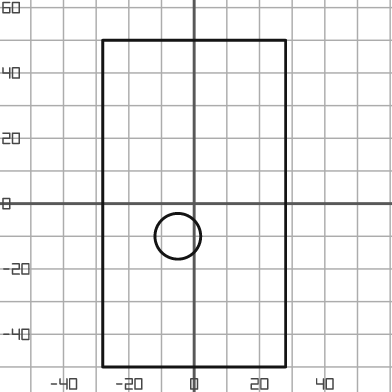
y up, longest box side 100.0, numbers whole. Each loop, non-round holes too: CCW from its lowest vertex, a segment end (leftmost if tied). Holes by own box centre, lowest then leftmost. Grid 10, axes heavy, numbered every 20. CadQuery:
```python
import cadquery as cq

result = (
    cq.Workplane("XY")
    .moveTo(-28.0, -50.0)
    .lineTo(28.0, -50.0)
    .lineTo(28.0, 50.0)
    .lineTo(-28.0, 50.0)
    .close()
    .moveTo(-5.0, -10.0)
    .circle(7.0)
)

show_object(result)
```